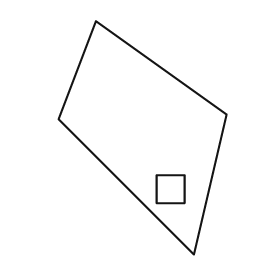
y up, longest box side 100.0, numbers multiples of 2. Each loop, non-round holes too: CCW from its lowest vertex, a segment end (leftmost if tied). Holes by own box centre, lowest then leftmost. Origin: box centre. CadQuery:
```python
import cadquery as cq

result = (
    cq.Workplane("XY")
    .moveTo(22.0, -50.0)
    .lineTo(36.0, 10.0)
    .lineTo(-20.0, 50.0)
    .lineTo(-36.0, 8.0)
    .close()
    .moveTo(6.0, -28.0)
    .lineTo(18.0, -28.0)
    .lineTo(18.0, -16.0)
    .lineTo(6.0, -16.0)
    .close()
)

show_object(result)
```